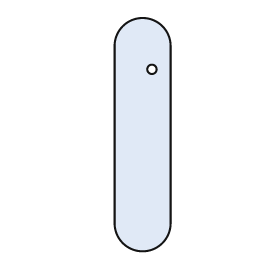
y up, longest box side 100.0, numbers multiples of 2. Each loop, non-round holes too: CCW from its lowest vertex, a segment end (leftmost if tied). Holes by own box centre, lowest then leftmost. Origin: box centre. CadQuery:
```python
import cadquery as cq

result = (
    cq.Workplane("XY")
    .moveTo(-12.0, -38.0)
    .threePointArc((0.0, -50.0), (12.0, -38.0))
    .lineTo(12.0, 38.0)
    .threePointArc((0.0, 50.0), (-12.0, 38.0))
    .close()
    .moveTo(4.0, 28.0)
    .circle(2.0)
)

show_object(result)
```